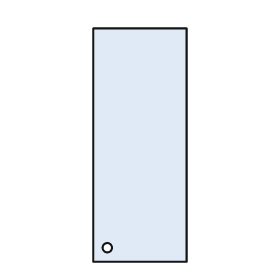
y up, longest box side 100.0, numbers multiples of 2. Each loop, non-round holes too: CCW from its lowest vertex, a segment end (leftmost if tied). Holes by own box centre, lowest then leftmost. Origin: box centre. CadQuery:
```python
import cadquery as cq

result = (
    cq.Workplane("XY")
    .moveTo(-20.0, -50.0)
    .lineTo(20.0, -50.0)
    .lineTo(20.0, 50.0)
    .lineTo(-20.0, 50.0)
    .close()
    .moveTo(-14.0, -44.0)
    .circle(2.0)
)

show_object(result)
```